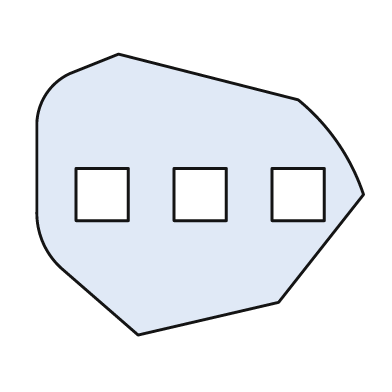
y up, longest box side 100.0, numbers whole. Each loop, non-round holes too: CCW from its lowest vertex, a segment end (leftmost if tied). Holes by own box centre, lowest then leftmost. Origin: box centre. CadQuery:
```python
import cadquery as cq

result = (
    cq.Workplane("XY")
    .moveTo(-19.0, -43.0)
    .lineTo(24.0, -33.0)
    .lineTo(50.0, 0.0)
    .threePointArc((42.0, 16.0), (30.0, 29.0))
    .lineTo(-25.0, 43.0)
    .lineTo(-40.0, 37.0)
    .threePointArc((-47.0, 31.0), (-50.0, 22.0))
    .lineTo(-50.0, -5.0)
    .threePointArc((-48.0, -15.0), (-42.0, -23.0))
    .close()
    .moveTo(-38.0, -8.0)
    .lineTo(-22.0, -8.0)
    .lineTo(-22.0, 8.0)
    .lineTo(-38.0, 8.0)
    .close()
    .moveTo(-8.0, -8.0)
    .lineTo(8.0, -8.0)
    .lineTo(8.0, 8.0)
    .lineTo(-8.0, 8.0)
    .close()
    .moveTo(22.0, -8.0)
    .lineTo(38.0, -8.0)
    .lineTo(38.0, 8.0)
    .lineTo(22.0, 8.0)
    .close()
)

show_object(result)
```